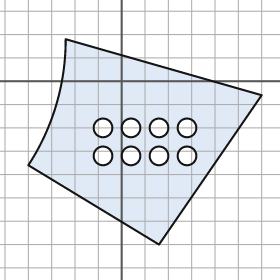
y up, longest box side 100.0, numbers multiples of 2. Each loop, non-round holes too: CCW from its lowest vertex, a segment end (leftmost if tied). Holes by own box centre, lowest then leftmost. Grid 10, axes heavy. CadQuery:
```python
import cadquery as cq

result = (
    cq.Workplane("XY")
    .moveTo(16.0, -70.0)
    .lineTo(60.0, -6.0)
    .lineTo(-24.0, 18.0)
    .threePointArc((-28.0, -10.0), (-40.0, -36.0))
    .close()
    .moveTo(-8.0, -32.0)
    .circle(4.0)
    .moveTo(4.0, -32.0)
    .circle(4.0)
    .moveTo(16.0, -32.0)
    .circle(4.0)
    .moveTo(28.0, -32.0)
    .circle(4.0)
    .moveTo(-8.0, -20.0)
    .circle(4.0)
    .moveTo(4.0, -20.0)
    .circle(4.0)
    .moveTo(16.0, -20.0)
    .circle(4.0)
    .moveTo(28.0, -20.0)
    .circle(4.0)
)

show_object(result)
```